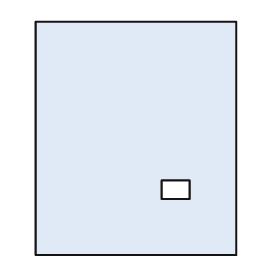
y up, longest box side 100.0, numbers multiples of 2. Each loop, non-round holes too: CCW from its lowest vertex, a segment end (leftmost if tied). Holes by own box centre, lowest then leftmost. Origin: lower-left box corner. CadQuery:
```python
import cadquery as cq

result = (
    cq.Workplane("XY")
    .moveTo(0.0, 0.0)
    .lineTo(86.0, 0.0)
    .lineTo(86.0, 100.0)
    .lineTo(0.0, 100.0)
    .close()
    .moveTo(54.0, 24.0)
    .lineTo(66.0, 24.0)
    .lineTo(66.0, 32.0)
    .lineTo(54.0, 32.0)
    .close()
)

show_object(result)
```